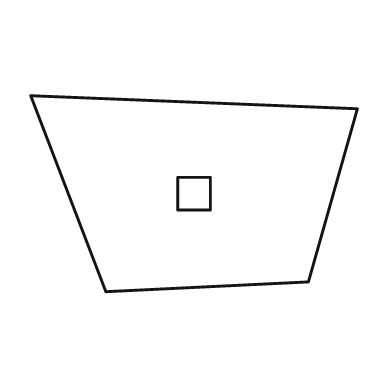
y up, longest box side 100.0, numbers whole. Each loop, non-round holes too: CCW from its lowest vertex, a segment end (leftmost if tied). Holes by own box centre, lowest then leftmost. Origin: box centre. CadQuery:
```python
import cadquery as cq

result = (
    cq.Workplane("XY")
    .moveTo(-27.0, -30.0)
    .lineTo(35.0, -27.0)
    .lineTo(50.0, 26.0)
    .lineTo(-50.0, 30.0)
    .close()
    .moveTo(-5.0, -5.0)
    .lineTo(5.0, -5.0)
    .lineTo(5.0, 5.0)
    .lineTo(-5.0, 5.0)
    .close()
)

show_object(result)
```